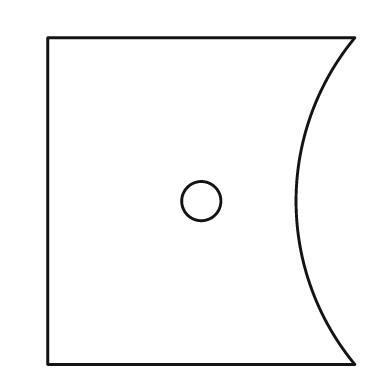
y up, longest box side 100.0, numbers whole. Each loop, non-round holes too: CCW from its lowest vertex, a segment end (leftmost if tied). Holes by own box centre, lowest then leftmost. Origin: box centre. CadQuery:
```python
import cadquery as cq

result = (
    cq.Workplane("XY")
    .moveTo(-47.0, -50.0)
    .lineTo(47.0, -50.0)
    .threePointArc((29.0, 0.0), (47.0, 50.0))
    .lineTo(-47.0, 50.0)
    .close()
    .moveTo(0.0, 0.0)
    .circle(6.0)
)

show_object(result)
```